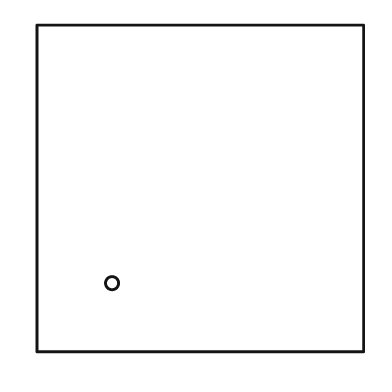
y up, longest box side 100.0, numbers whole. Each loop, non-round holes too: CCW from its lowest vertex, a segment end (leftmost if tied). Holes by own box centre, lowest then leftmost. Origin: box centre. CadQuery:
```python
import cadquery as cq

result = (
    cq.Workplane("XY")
    .moveTo(-50.0, -50.0)
    .lineTo(50.0, -50.0)
    .lineTo(50.0, 50.0)
    .lineTo(-50.0, 50.0)
    .close()
    .moveTo(-27.0, -29.0)
    .circle(2.0)
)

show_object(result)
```